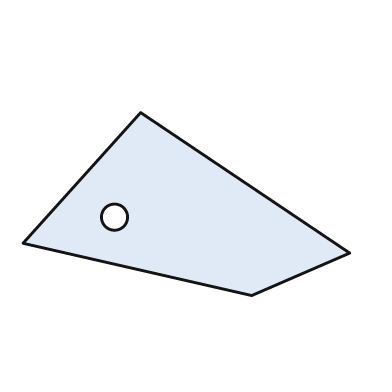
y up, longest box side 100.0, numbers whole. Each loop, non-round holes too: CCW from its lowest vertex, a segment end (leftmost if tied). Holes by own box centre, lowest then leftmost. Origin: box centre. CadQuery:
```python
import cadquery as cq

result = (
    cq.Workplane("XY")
    .moveTo(20.0, -28.0)
    .lineTo(50.0, -15.0)
    .lineTo(-14.0, 28.0)
    .lineTo(-50.0, -12.0)
    .close()
    .moveTo(-22.0, -4.0)
    .circle(4.0)
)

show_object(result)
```